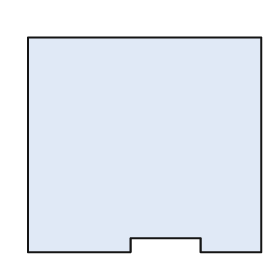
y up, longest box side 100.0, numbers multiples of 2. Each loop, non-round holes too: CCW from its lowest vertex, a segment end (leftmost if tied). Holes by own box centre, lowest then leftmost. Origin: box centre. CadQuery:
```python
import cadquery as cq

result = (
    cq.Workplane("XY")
    .moveTo(-50.0, -46.0)
    .lineTo(-6.0, -46.0)
    .lineTo(-6.0, -40.0)
    .lineTo(24.0, -40.0)
    .lineTo(24.0, -46.0)
    .lineTo(50.0, -46.0)
    .lineTo(50.0, 46.0)
    .lineTo(-50.0, 46.0)
    .close()
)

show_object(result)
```